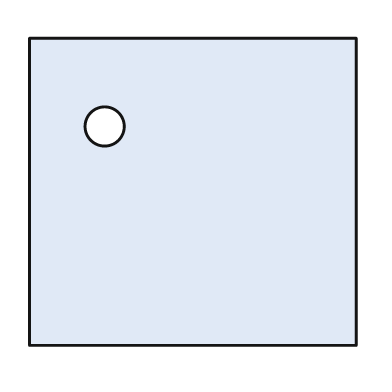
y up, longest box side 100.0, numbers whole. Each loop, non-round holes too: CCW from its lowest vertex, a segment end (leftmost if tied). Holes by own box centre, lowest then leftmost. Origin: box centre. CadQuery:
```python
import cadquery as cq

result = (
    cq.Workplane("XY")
    .moveTo(-50.0, -47.0)
    .lineTo(50.0, -47.0)
    .lineTo(50.0, 47.0)
    .lineTo(-50.0, 47.0)
    .close()
    .moveTo(-27.0, 20.0)
    .circle(6.0)
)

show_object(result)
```